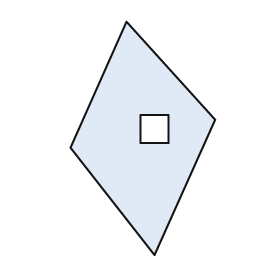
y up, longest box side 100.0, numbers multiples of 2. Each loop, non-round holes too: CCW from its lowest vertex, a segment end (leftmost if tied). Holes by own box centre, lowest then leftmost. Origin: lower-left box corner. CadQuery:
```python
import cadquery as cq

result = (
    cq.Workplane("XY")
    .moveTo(36.0, 0.0)
    .lineTo(62.0, 58.0)
    .lineTo(24.0, 100.0)
    .lineTo(0.0, 46.0)
    .close()
    .moveTo(30.0, 48.0)
    .lineTo(42.0, 48.0)
    .lineTo(42.0, 60.0)
    .lineTo(30.0, 60.0)
    .close()
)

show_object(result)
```